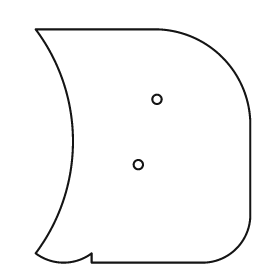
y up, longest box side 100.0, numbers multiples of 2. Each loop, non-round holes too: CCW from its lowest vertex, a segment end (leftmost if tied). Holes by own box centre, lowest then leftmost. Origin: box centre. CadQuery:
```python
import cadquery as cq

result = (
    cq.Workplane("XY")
    .moveTo(-22.0, -50.0)
    .lineTo(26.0, -50.0)
    .threePointArc((40.0, -44.0), (46.0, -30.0))
    .lineTo(46.0, 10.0)
    .threePointArc((34.0, 38.0), (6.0, 50.0))
    .lineTo(-46.0, 50.0)
    .threePointArc((-30.0, 2.0), (-46.0, -46.0))
    .threePointArc((-34.0, -50.0), (-22.0, -46.0))
    .close()
    .moveTo(-2.0, -8.0)
    .circle(2.0)
    .moveTo(6.0, 20.0)
    .circle(2.0)
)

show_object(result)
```